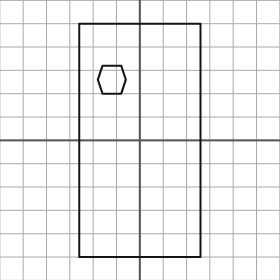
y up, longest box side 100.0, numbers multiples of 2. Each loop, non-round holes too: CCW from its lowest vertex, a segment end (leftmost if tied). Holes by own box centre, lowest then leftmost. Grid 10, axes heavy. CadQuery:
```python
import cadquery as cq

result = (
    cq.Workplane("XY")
    .moveTo(-26.0, -50.0)
    .lineTo(26.0, -50.0)
    .lineTo(26.0, 50.0)
    .lineTo(-26.0, 50.0)
    .close()
    .moveTo(-16.0, 20.0)
    .lineTo(-8.0, 20.0)
    .lineTo(-6.0, 26.0)
    .lineTo(-8.0, 32.0)
    .lineTo(-16.0, 32.0)
    .lineTo(-18.0, 26.0)
    .close()
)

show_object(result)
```